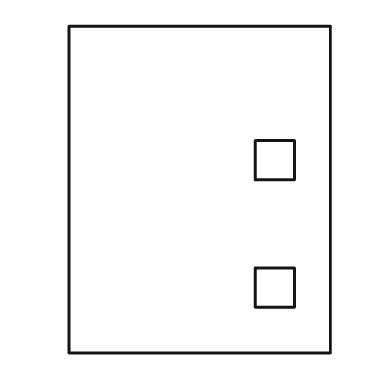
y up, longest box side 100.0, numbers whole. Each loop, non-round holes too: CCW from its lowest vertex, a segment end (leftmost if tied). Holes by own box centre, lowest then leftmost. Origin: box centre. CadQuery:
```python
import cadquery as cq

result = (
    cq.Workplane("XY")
    .moveTo(-40.0, -50.0)
    .lineTo(40.0, -50.0)
    .lineTo(40.0, 50.0)
    .lineTo(-40.0, 50.0)
    .close()
    .moveTo(17.0, -36.0)
    .lineTo(29.0, -36.0)
    .lineTo(29.0, -24.0)
    .lineTo(17.0, -24.0)
    .close()
    .moveTo(17.0, 3.0)
    .lineTo(29.0, 3.0)
    .lineTo(29.0, 15.0)
    .lineTo(17.0, 15.0)
    .close()
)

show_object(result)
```